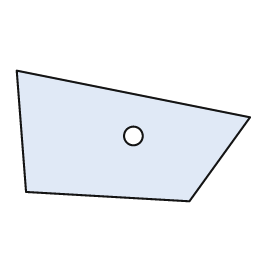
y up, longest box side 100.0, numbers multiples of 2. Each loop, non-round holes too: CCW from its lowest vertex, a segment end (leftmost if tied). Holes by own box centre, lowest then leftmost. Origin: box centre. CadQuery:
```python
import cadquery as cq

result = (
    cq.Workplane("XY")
    .moveTo(24.0, -28.0)
    .lineTo(50.0, 8.0)
    .lineTo(-50.0, 28.0)
    .lineTo(-46.0, -24.0)
    .close()
    .moveTo(0.0, 0.0)
    .circle(4.0)
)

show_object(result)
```